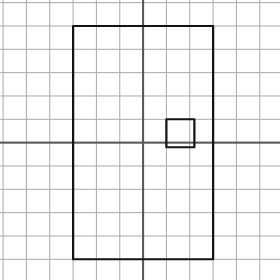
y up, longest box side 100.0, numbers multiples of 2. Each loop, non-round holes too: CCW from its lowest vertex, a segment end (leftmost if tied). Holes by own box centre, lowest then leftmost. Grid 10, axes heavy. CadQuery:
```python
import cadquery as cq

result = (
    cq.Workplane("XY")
    .moveTo(-30.0, -50.0)
    .lineTo(30.0, -50.0)
    .lineTo(30.0, 50.0)
    .lineTo(-30.0, 50.0)
    .close()
    .moveTo(10.0, -2.0)
    .lineTo(22.0, -2.0)
    .lineTo(22.0, 10.0)
    .lineTo(10.0, 10.0)
    .close()
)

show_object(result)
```